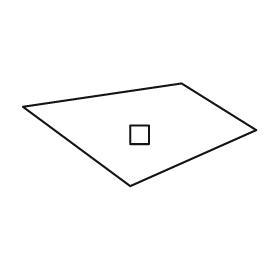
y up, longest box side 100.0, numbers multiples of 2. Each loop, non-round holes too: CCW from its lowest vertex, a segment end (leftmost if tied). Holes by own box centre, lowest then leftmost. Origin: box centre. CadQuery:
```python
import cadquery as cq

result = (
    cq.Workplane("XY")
    .moveTo(-4.0, -22.0)
    .lineTo(50.0, 2.0)
    .lineTo(18.0, 22.0)
    .lineTo(-50.0, 12.0)
    .close()
    .moveTo(-4.0, -4.0)
    .lineTo(4.0, -4.0)
    .lineTo(4.0, 4.0)
    .lineTo(-4.0, 4.0)
    .close()
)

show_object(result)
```